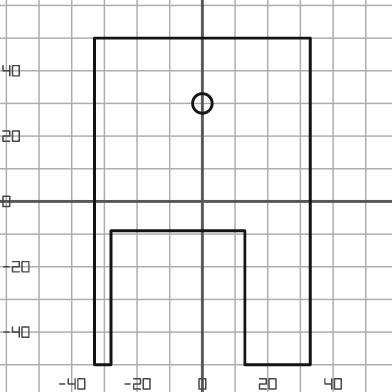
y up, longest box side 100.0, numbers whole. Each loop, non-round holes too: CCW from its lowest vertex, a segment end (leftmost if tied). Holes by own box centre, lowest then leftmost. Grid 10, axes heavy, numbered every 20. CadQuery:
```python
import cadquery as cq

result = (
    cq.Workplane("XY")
    .moveTo(-33.0, -50.0)
    .lineTo(-28.0, -50.0)
    .lineTo(-28.0, -9.0)
    .lineTo(13.0, -9.0)
    .lineTo(13.0, -50.0)
    .lineTo(33.0, -50.0)
    .lineTo(33.0, 50.0)
    .lineTo(-33.0, 50.0)
    .close()
    .moveTo(0.0, 30.0)
    .circle(3.0)
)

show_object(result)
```